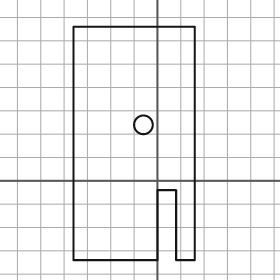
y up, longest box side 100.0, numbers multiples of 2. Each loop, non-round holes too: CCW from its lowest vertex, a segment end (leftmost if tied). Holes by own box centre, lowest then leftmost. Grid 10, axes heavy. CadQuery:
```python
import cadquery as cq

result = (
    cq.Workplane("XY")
    .moveTo(-36.0, -34.0)
    .lineTo(0.0, -34.0)
    .lineTo(0.0, -4.0)
    .lineTo(8.0, -4.0)
    .lineTo(8.0, -34.0)
    .lineTo(16.0, -34.0)
    .lineTo(16.0, 66.0)
    .lineTo(-36.0, 66.0)
    .close()
    .moveTo(-6.0, 24.0)
    .circle(4.0)
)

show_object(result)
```